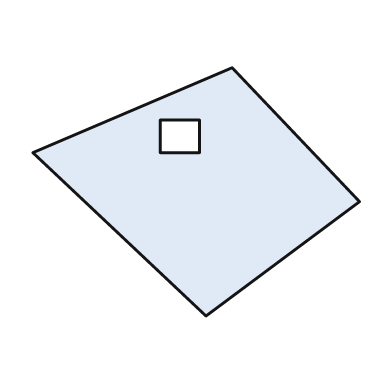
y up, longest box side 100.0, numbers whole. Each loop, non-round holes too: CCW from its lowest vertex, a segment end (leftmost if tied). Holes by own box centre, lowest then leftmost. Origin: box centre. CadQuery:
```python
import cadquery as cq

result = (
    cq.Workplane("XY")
    .moveTo(3.0, -38.0)
    .lineTo(50.0, -3.0)
    .lineTo(11.0, 38.0)
    .lineTo(-50.0, 12.0)
    .close()
    .moveTo(-11.0, 12.0)
    .lineTo(1.0, 12.0)
    .lineTo(1.0, 22.0)
    .lineTo(-11.0, 22.0)
    .close()
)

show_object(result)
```